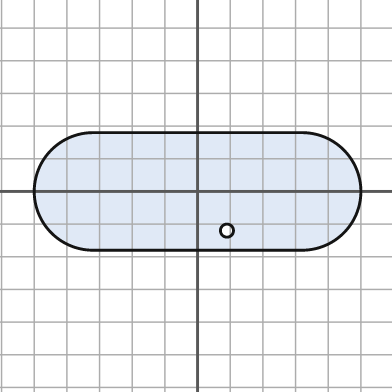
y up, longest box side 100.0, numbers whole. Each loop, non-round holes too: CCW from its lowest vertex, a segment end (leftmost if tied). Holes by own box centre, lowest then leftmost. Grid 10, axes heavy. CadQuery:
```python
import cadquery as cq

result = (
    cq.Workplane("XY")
    .moveTo(-32.0, -18.0)
    .lineTo(32.0, -18.0)
    .threePointArc((50.0, 0.0), (32.0, 18.0))
    .lineTo(-32.0, 18.0)
    .threePointArc((-50.0, 0.0), (-32.0, -18.0))
    .close()
    .moveTo(9.0, -12.0)
    .circle(2.0)
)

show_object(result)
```